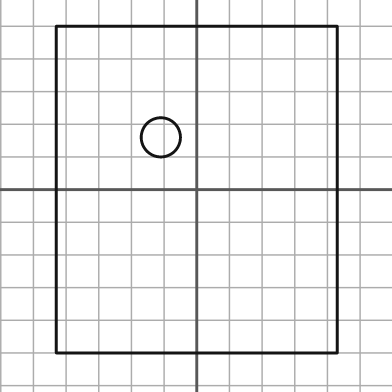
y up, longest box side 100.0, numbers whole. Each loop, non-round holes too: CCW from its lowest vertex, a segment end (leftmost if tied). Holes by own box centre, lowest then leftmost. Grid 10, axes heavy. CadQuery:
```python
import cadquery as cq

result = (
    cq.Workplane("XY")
    .moveTo(-43.0, -50.0)
    .lineTo(43.0, -50.0)
    .lineTo(43.0, 50.0)
    .lineTo(-43.0, 50.0)
    .close()
    .moveTo(-11.0, 16.0)
    .circle(6.0)
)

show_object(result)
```